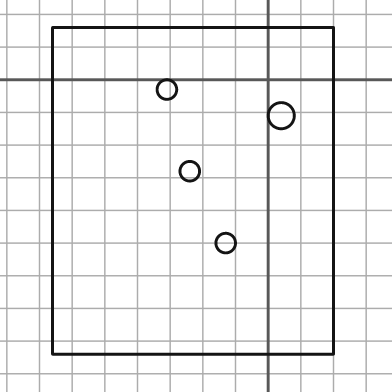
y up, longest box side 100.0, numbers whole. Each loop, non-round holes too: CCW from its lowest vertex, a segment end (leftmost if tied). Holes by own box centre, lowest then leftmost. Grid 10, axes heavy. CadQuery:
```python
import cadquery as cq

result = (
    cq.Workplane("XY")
    .moveTo(-66.0, -84.0)
    .lineTo(20.0, -84.0)
    .lineTo(20.0, 16.0)
    .lineTo(-66.0, 16.0)
    .close()
    .moveTo(-13.0, -50.0)
    .circle(3.0)
    .moveTo(-24.0, -28.0)
    .circle(3.0)
    .moveTo(4.0, -11.0)
    .circle(4.0)
    .moveTo(-31.0, -3.0)
    .circle(3.0)
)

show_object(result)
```